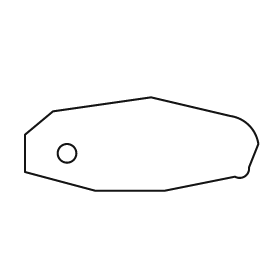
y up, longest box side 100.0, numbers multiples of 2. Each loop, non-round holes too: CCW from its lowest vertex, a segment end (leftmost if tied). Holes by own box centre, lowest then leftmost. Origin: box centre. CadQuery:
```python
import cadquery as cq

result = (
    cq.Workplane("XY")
    .moveTo(-20.0, -20.0)
    .lineTo(10.0, -20.0)
    .lineTo(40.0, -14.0)
    .threePointArc((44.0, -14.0), (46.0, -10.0))
    .lineTo(50.0, 0.0)
    .threePointArc((46.0, 8.0), (38.0, 12.0))
    .lineTo(4.0, 20.0)
    .lineTo(-38.0, 14.0)
    .lineTo(-50.0, 4.0)
    .lineTo(-50.0, -12.0)
    .close()
    .moveTo(-32.0, -4.0)
    .circle(4.0)
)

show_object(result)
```